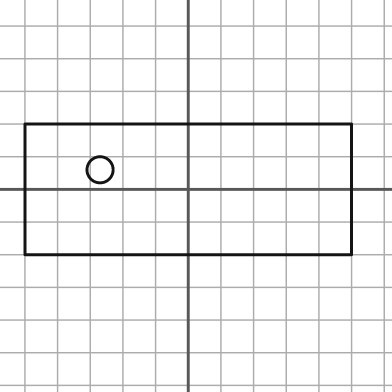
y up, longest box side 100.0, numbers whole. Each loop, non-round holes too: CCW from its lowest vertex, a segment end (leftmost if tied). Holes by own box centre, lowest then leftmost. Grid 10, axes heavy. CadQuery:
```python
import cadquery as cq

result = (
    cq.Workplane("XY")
    .moveTo(-50.0, -20.0)
    .lineTo(50.0, -20.0)
    .lineTo(50.0, 20.0)
    .lineTo(-50.0, 20.0)
    .close()
    .moveTo(-27.0, 6.0)
    .circle(4.0)
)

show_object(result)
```